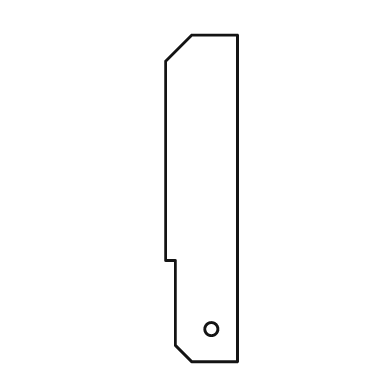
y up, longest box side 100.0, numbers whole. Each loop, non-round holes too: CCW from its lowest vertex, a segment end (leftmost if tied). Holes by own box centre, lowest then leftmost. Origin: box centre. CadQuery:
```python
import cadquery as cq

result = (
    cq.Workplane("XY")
    .moveTo(-3.0, -50.0)
    .lineTo(11.0, -50.0)
    .lineTo(11.0, 50.0)
    .lineTo(-3.0, 50.0)
    .lineTo(-11.0, 42.0)
    .lineTo(-11.0, -19.0)
    .lineTo(-8.0, -19.0)
    .lineTo(-8.0, -45.0)
    .close()
    .moveTo(3.0, -40.0)
    .circle(2.0)
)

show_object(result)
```